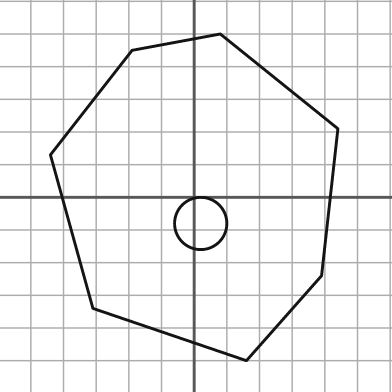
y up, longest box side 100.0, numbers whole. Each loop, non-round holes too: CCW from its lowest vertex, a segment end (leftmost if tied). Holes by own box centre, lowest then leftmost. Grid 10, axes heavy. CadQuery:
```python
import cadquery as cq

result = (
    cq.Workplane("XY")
    .moveTo(16.0, -50.0)
    .lineTo(39.0, -24.0)
    .lineTo(44.0, 21.0)
    .lineTo(8.0, 50.0)
    .lineTo(-19.0, 45.0)
    .lineTo(-44.0, 13.0)
    .lineTo(-31.0, -34.0)
    .close()
    .moveTo(2.0, -8.0)
    .circle(8.0)
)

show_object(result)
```